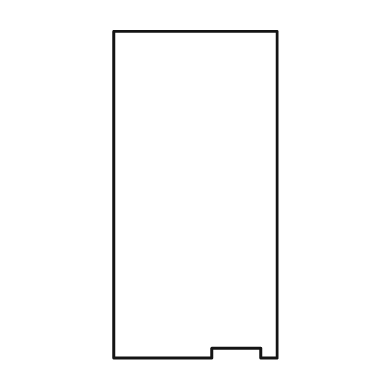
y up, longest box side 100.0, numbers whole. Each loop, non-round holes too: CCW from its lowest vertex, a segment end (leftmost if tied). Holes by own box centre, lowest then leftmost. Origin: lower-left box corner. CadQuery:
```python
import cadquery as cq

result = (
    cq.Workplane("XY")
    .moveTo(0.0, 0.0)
    .lineTo(30.0, 0.0)
    .lineTo(30.0, 3.0)
    .lineTo(45.0, 3.0)
    .lineTo(45.0, 0.0)
    .lineTo(50.0, 0.0)
    .lineTo(50.0, 100.0)
    .lineTo(0.0, 100.0)
    .close()
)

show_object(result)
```